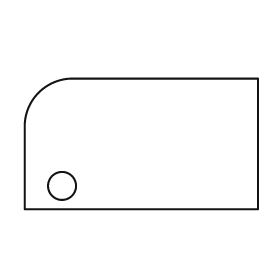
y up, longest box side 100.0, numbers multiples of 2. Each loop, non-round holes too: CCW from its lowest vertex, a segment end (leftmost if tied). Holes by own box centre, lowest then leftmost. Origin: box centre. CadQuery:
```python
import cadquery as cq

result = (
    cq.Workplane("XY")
    .moveTo(-50.0, -28.0)
    .lineTo(50.0, -28.0)
    .lineTo(50.0, 28.0)
    .lineTo(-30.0, 28.0)
    .threePointArc((-44.0, 22.0), (-50.0, 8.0))
    .close()
    .moveTo(-34.0, -18.0)
    .circle(6.0)
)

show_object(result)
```